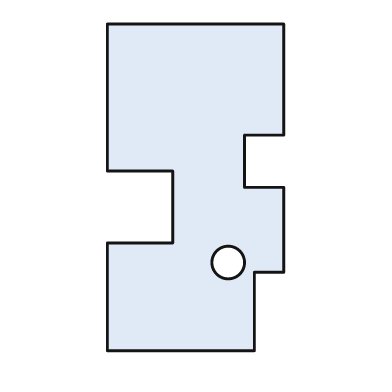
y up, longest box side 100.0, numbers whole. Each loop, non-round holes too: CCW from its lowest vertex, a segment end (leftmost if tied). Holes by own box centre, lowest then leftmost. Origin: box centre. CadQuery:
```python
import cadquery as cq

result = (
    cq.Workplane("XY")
    .moveTo(-27.0, -50.0)
    .lineTo(18.0, -50.0)
    .lineTo(18.0, -26.0)
    .lineTo(27.0, -26.0)
    .lineTo(27.0, 0.0)
    .lineTo(15.0, 0.0)
    .lineTo(15.0, 16.0)
    .lineTo(27.0, 16.0)
    .lineTo(27.0, 50.0)
    .lineTo(-27.0, 50.0)
    .lineTo(-27.0, 5.0)
    .lineTo(-7.0, 5.0)
    .lineTo(-7.0, -17.0)
    .lineTo(-27.0, -17.0)
    .close()
    .moveTo(10.0, -23.0)
    .circle(5.0)
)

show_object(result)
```